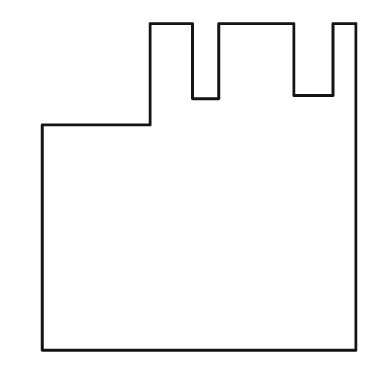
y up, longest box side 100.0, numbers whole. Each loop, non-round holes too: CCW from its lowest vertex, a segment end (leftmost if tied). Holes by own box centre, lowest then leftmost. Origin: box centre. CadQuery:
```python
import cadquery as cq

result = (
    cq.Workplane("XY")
    .moveTo(-48.0, -50.0)
    .lineTo(48.0, -50.0)
    .lineTo(48.0, 50.0)
    .lineTo(41.0, 50.0)
    .lineTo(41.0, 28.0)
    .lineTo(29.0, 28.0)
    .lineTo(29.0, 50.0)
    .lineTo(6.0, 50.0)
    .lineTo(6.0, 27.0)
    .lineTo(-2.0, 27.0)
    .lineTo(-2.0, 50.0)
    .lineTo(-15.0, 50.0)
    .lineTo(-15.0, 19.0)
    .lineTo(-48.0, 19.0)
    .close()
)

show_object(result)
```